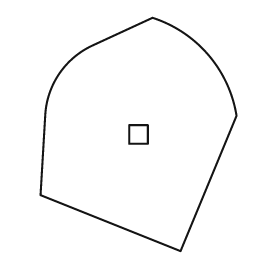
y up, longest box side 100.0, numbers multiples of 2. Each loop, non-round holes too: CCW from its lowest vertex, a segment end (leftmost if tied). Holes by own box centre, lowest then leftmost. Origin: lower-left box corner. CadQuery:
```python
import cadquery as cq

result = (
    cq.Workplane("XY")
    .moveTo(60.0, 0.0)
    .lineTo(84.0, 58.0)
    .threePointArc((72.0, 84.0), (48.0, 100.0))
    .lineTo(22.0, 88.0)
    .threePointArc((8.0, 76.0), (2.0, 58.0))
    .lineTo(0.0, 24.0)
    .close()
    .moveTo(38.0, 46.0)
    .lineTo(46.0, 46.0)
    .lineTo(46.0, 54.0)
    .lineTo(38.0, 54.0)
    .close()
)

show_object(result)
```